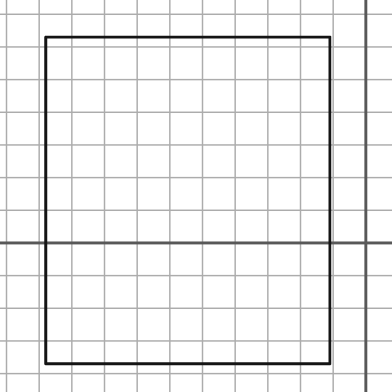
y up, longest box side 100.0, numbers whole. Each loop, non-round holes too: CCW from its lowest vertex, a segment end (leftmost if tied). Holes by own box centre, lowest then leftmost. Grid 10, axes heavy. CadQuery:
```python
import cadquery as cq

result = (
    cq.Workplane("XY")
    .moveTo(-98.0, -37.0)
    .lineTo(-11.0, -37.0)
    .lineTo(-11.0, 63.0)
    .lineTo(-98.0, 63.0)
    .close()
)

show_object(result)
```